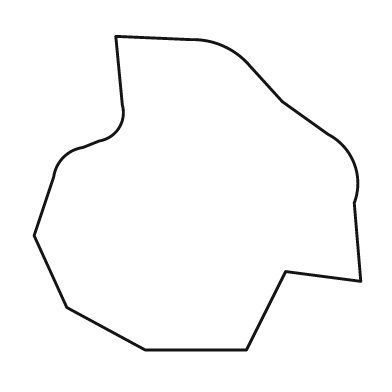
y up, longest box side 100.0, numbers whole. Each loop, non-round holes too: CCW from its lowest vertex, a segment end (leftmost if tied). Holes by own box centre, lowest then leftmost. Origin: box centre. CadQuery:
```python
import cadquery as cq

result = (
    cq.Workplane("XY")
    .moveTo(-16.0, -48.0)
    .lineTo(15.0, -48.0)
    .lineTo(27.0, -24.0)
    .lineTo(50.0, -27.0)
    .lineTo(48.0, -3.0)
    .threePointArc((48.0, 9.0), (40.0, 18.0))
    .lineTo(26.0, 28.0)
    .lineTo(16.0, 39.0)
    .threePointArc((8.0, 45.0), (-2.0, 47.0))
    .lineTo(-25.0, 48.0)
    .lineTo(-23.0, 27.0)
    .threePointArc((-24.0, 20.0), (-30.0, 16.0))
    .lineTo(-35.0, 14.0)
    .threePointArc((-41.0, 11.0), (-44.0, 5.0))
    .lineTo(-50.0, -13.0)
    .lineTo(-40.0, -35.0)
    .close()
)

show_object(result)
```